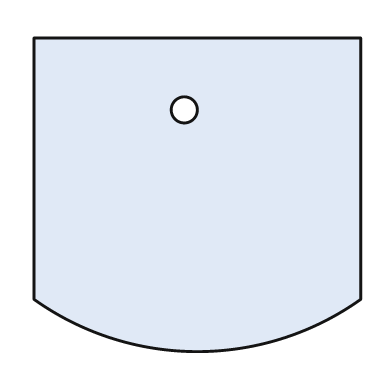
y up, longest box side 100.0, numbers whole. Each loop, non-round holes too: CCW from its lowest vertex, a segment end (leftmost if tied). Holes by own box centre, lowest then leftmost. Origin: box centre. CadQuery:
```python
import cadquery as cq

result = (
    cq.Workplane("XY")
    .moveTo(-50.0, -32.0)
    .threePointArc((0.0, -48.0), (50.0, -32.0))
    .lineTo(50.0, 48.0)
    .lineTo(-50.0, 48.0)
    .close()
    .moveTo(-4.0, 26.0)
    .circle(4.0)
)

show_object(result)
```